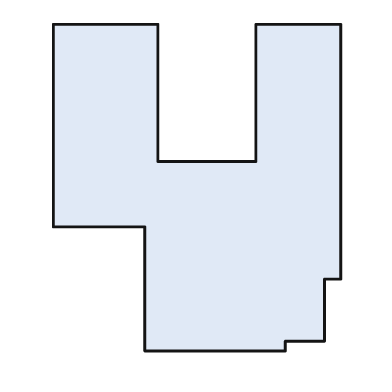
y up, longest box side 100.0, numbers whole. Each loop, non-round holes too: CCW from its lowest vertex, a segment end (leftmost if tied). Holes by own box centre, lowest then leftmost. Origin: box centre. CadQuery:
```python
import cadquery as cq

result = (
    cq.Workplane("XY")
    .moveTo(-16.0, -50.0)
    .lineTo(27.0, -50.0)
    .lineTo(27.0, -47.0)
    .lineTo(39.0, -47.0)
    .lineTo(39.0, -28.0)
    .lineTo(44.0, -28.0)
    .lineTo(44.0, 50.0)
    .lineTo(18.0, 50.0)
    .lineTo(18.0, 8.0)
    .lineTo(-12.0, 8.0)
    .lineTo(-12.0, 50.0)
    .lineTo(-44.0, 50.0)
    .lineTo(-44.0, -12.0)
    .lineTo(-16.0, -12.0)
    .close()
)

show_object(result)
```